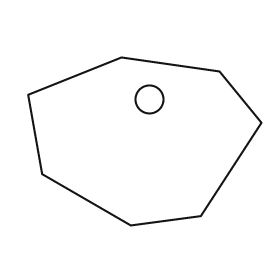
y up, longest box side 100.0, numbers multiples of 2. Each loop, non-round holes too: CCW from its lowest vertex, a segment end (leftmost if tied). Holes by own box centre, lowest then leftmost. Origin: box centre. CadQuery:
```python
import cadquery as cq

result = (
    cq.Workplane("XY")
    .moveTo(-6.0, -36.0)
    .lineTo(24.0, -32.0)
    .lineTo(50.0, 8.0)
    .lineTo(32.0, 30.0)
    .lineTo(-10.0, 36.0)
    .lineTo(-50.0, 20.0)
    .lineTo(-44.0, -14.0)
    .close()
    .moveTo(2.0, 18.0)
    .circle(6.0)
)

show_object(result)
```